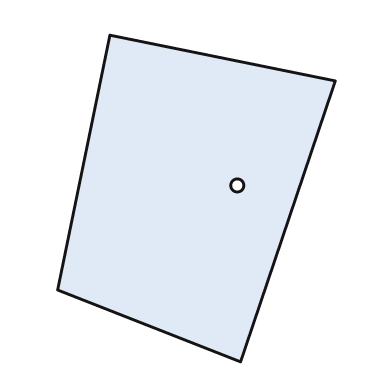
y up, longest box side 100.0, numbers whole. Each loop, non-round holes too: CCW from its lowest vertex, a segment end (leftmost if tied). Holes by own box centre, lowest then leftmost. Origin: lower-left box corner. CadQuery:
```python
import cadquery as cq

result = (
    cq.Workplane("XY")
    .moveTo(56.0, 0.0)
    .lineTo(85.0, 86.0)
    .lineTo(16.0, 100.0)
    .lineTo(0.0, 22.0)
    .close()
    .moveTo(55.0, 54.0)
    .circle(2.0)
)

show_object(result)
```